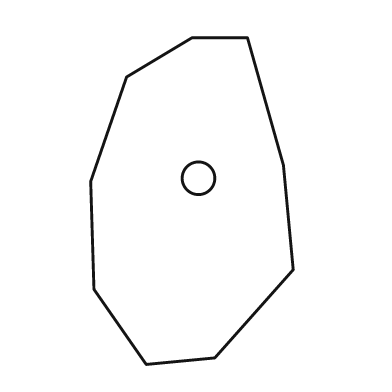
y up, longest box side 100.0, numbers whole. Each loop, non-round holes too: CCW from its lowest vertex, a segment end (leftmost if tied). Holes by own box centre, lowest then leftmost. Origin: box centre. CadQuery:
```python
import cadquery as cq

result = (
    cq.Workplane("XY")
    .moveTo(-14.0, -50.0)
    .lineTo(7.0, -48.0)
    .lineTo(31.0, -21.0)
    .lineTo(28.0, 11.0)
    .lineTo(17.0, 50.0)
    .lineTo(0.0, 50.0)
    .lineTo(-20.0, 38.0)
    .lineTo(-31.0, 6.0)
    .lineTo(-30.0, -27.0)
    .close()
    .moveTo(2.0, 7.0)
    .circle(5.0)
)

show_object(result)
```